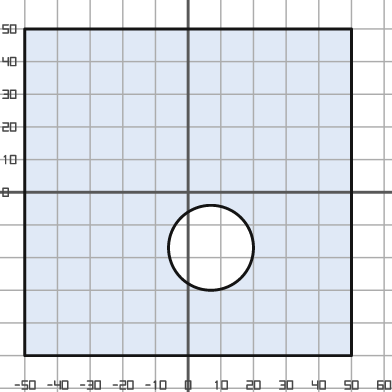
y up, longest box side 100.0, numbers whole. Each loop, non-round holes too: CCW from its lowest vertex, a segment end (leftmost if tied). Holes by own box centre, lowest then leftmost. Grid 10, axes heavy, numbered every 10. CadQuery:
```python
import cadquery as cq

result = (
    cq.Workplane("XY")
    .moveTo(-50.0, -50.0)
    .lineTo(50.0, -50.0)
    .lineTo(50.0, 50.0)
    .lineTo(-50.0, 50.0)
    .close()
    .moveTo(7.0, -17.0)
    .circle(13.0)
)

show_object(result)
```